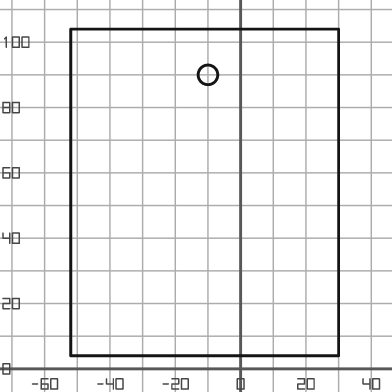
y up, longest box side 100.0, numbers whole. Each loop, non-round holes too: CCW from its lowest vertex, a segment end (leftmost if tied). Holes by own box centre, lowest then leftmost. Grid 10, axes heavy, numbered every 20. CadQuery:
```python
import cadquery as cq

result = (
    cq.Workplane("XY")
    .moveTo(-52.0, 4.0)
    .lineTo(30.0, 4.0)
    .lineTo(30.0, 104.0)
    .lineTo(-52.0, 104.0)
    .close()
    .moveTo(-10.0, 90.0)
    .circle(3.0)
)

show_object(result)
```